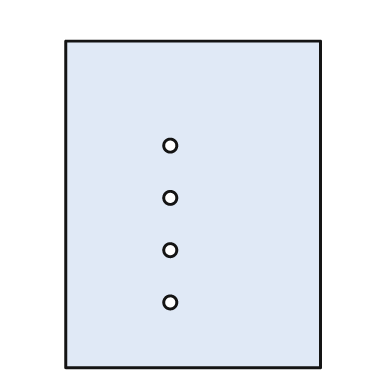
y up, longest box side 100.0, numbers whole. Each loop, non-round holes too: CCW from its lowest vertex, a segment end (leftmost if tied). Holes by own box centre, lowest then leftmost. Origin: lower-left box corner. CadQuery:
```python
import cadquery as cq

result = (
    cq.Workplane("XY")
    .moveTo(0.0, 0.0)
    .lineTo(78.0, 0.0)
    .lineTo(78.0, 100.0)
    .lineTo(0.0, 100.0)
    .close()
    .moveTo(32.0, 20.0)
    .circle(2.0)
    .moveTo(32.0, 36.0)
    .circle(2.0)
    .moveTo(32.0, 52.0)
    .circle(2.0)
    .moveTo(32.0, 68.0)
    .circle(2.0)
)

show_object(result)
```